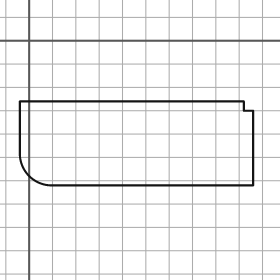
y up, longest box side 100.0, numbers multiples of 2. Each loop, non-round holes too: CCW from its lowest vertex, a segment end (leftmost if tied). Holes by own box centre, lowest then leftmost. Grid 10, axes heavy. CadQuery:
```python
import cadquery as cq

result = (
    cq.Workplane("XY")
    .moveTo(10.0, -62.0)
    .lineTo(96.0, -62.0)
    .lineTo(96.0, -30.0)
    .lineTo(92.0, -30.0)
    .lineTo(92.0, -26.0)
    .lineTo(-4.0, -26.0)
    .lineTo(-4.0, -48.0)
    .threePointArc((0.0, -58.0), (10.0, -62.0))
    .close()
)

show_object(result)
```